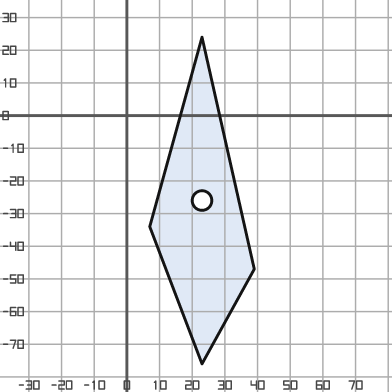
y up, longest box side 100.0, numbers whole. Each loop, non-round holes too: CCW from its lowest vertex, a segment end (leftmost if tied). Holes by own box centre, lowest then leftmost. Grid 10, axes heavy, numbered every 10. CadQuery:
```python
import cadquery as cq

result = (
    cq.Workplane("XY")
    .moveTo(23.0, -76.0)
    .lineTo(39.0, -47.0)
    .lineTo(23.0, 24.0)
    .lineTo(7.0, -34.0)
    .close()
    .moveTo(23.0, -26.0)
    .circle(3.0)
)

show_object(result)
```